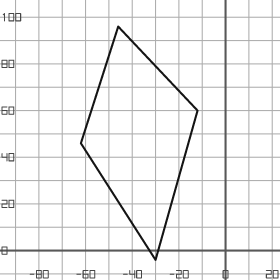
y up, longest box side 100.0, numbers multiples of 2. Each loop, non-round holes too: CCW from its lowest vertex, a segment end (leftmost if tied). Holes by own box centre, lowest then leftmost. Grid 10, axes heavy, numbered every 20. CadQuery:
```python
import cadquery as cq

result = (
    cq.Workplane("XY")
    .moveTo(-30.0, -4.0)
    .lineTo(-12.0, 60.0)
    .lineTo(-46.0, 96.0)
    .lineTo(-62.0, 46.0)
    .close()
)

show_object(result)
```